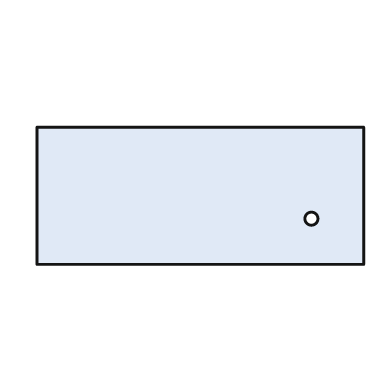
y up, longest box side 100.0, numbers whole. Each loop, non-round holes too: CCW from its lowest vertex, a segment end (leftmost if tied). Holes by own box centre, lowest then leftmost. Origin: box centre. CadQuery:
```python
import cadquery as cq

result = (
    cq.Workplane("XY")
    .moveTo(-50.0, -21.0)
    .lineTo(50.0, -21.0)
    .lineTo(50.0, 21.0)
    .lineTo(-50.0, 21.0)
    .close()
    .moveTo(34.0, -7.0)
    .circle(2.0)
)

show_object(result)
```